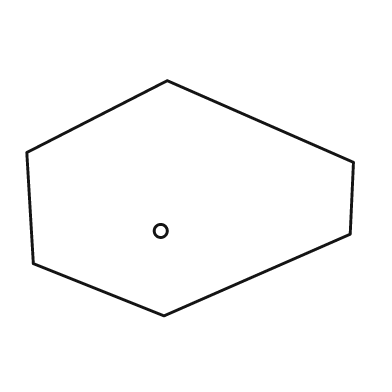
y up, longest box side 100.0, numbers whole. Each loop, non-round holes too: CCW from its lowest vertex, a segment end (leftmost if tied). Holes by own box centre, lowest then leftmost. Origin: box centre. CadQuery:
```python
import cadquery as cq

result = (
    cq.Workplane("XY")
    .moveTo(-8.0, -36.0)
    .lineTo(49.0, -11.0)
    .lineTo(50.0, 11.0)
    .lineTo(-7.0, 36.0)
    .lineTo(-50.0, 14.0)
    .lineTo(-48.0, -20.0)
    .close()
    .moveTo(-9.0, -10.0)
    .circle(2.0)
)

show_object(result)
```